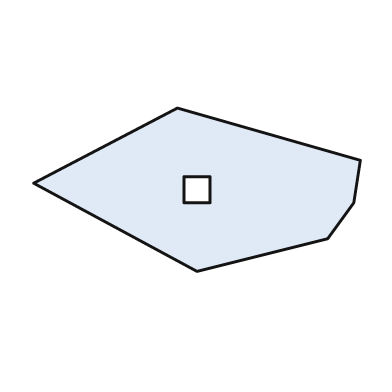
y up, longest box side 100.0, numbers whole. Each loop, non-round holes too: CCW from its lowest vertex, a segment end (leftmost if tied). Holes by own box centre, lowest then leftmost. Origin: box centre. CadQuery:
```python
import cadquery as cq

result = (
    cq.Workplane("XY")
    .moveTo(0.0, -25.0)
    .lineTo(40.0, -15.0)
    .lineTo(48.0, -4.0)
    .lineTo(50.0, 9.0)
    .lineTo(-6.0, 25.0)
    .lineTo(-50.0, 2.0)
    .close()
    .moveTo(-4.0, -4.0)
    .lineTo(4.0, -4.0)
    .lineTo(4.0, 4.0)
    .lineTo(-4.0, 4.0)
    .close()
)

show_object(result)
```